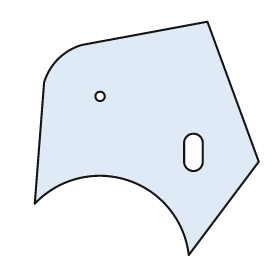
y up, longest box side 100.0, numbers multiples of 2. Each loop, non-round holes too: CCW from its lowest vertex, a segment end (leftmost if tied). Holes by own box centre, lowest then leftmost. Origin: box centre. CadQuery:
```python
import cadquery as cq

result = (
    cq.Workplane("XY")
    .moveTo(18.0, -50.0)
    .lineTo(48.0, -10.0)
    .lineTo(26.0, 50.0)
    .lineTo(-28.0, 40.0)
    .threePointArc((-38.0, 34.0), (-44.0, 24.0))
    .lineTo(-48.0, -28.0)
    .threePointArc((-8.0, -18.0), (18.0, -50.0))
    .close()
    .moveTo(16.0, -10.0)
    .threePointArc((20.0, -14.0), (24.0, -10.0))
    .lineTo(24.0, -2.0)
    .threePointArc((20.0, 2.0), (16.0, -2.0))
    .close()
    .moveTo(-20.0, 18.0)
    .circle(2.0)
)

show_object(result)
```